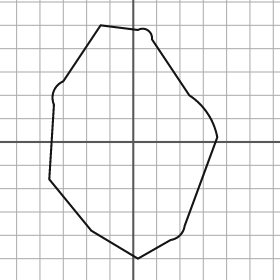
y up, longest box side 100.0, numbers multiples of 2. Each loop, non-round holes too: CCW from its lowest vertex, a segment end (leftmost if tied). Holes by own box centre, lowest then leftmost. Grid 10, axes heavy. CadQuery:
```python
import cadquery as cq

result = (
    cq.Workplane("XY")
    .moveTo(2.0, -50.0)
    .lineTo(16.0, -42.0)
    .threePointArc((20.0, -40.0), (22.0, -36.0))
    .lineTo(36.0, 2.0)
    .threePointArc((32.0, 12.0), (24.0, 20.0))
    .lineTo(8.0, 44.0)
    .threePointArc((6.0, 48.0), (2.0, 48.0))
    .lineTo(-14.0, 50.0)
    .lineTo(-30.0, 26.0)
    .threePointArc((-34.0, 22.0), (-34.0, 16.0))
    .lineTo(-36.0, -16.0)
    .lineTo(-18.0, -38.0)
    .close()
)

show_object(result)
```